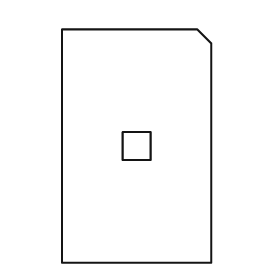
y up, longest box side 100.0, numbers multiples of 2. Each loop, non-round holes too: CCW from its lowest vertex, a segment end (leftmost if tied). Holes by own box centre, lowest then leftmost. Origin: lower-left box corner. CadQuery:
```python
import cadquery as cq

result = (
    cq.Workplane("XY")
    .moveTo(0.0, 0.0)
    .lineTo(64.0, 0.0)
    .lineTo(64.0, 94.0)
    .lineTo(58.0, 100.0)
    .lineTo(0.0, 100.0)
    .close()
    .moveTo(26.0, 44.0)
    .lineTo(38.0, 44.0)
    .lineTo(38.0, 56.0)
    .lineTo(26.0, 56.0)
    .close()
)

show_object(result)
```